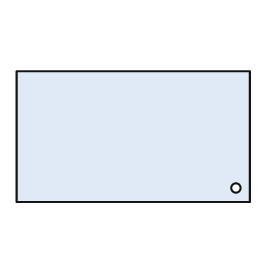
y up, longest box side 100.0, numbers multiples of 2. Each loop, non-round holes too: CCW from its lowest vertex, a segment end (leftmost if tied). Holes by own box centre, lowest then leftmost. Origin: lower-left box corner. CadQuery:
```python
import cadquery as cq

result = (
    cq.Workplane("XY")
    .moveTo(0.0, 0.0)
    .lineTo(100.0, 0.0)
    .lineTo(100.0, 56.0)
    .lineTo(0.0, 56.0)
    .close()
    .moveTo(94.0, 6.0)
    .circle(2.0)
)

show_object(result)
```